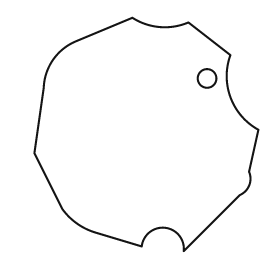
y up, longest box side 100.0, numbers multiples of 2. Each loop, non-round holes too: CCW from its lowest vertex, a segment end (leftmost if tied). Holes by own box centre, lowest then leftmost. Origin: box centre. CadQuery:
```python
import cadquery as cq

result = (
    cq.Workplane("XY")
    .moveTo(16.0, -50.0)
    .lineTo(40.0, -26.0)
    .threePointArc((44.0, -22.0), (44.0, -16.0))
    .lineTo(48.0, 2.0)
    .threePointArc((36.0, 16.0), (36.0, 34.0))
    .lineTo(18.0, 48.0)
    .threePointArc((6.0, 46.0), (-6.0, 50.0))
    .lineTo(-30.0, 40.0)
    .threePointArc((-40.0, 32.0), (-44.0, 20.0))
    .lineTo(-48.0, -8.0)
    .lineTo(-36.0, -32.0)
    .threePointArc((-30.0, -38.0), (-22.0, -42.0))
    .lineTo(-2.0, -48.0)
    .threePointArc((8.0, -40.0), (16.0, -50.0))
    .close()
    .moveTo(26.0, 24.0)
    .circle(4.0)
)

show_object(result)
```